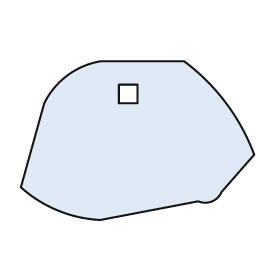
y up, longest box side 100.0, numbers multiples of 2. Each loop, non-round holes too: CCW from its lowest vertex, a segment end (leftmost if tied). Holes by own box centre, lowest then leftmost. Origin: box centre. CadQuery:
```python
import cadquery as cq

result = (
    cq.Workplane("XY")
    .moveTo(-16.0, -34.0)
    .lineTo(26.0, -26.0)
    .threePointArc((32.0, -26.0), (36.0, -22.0))
    .lineTo(50.0, -6.0)
    .threePointArc((38.0, 16.0), (20.0, 34.0))
    .lineTo(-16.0, 34.0)
    .threePointArc((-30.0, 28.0), (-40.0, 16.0))
    .lineTo(-50.0, -20.0)
    .threePointArc((-34.0, -30.0), (-16.0, -34.0))
    .close()
    .moveTo(-8.0, 16.0)
    .lineTo(0.0, 16.0)
    .lineTo(0.0, 24.0)
    .lineTo(-8.0, 24.0)
    .close()
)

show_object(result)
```